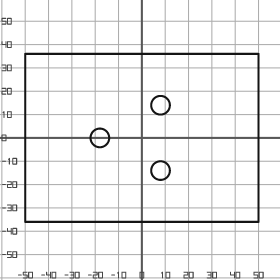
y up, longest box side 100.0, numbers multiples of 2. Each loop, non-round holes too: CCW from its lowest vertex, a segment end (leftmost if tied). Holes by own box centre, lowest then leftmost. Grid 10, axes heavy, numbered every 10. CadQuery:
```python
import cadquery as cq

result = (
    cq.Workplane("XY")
    .moveTo(-50.0, -36.0)
    .lineTo(50.0, -36.0)
    .lineTo(50.0, 36.0)
    .lineTo(-50.0, 36.0)
    .close()
    .moveTo(8.0, -14.0)
    .circle(4.0)
    .moveTo(-18.0, 0.0)
    .circle(4.0)
    .moveTo(8.0, 14.0)
    .circle(4.0)
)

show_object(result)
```